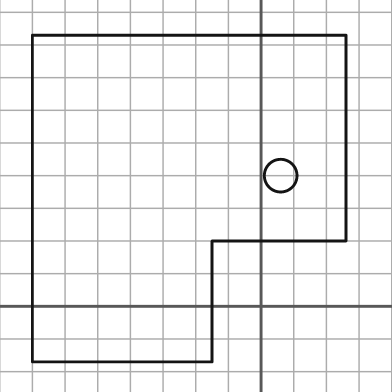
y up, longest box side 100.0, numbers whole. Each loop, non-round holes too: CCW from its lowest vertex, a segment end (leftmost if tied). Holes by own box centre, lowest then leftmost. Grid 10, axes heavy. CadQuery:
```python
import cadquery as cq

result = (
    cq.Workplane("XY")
    .moveTo(-70.0, -17.0)
    .lineTo(-15.0, -17.0)
    .lineTo(-15.0, 20.0)
    .lineTo(26.0, 20.0)
    .lineTo(26.0, 83.0)
    .lineTo(-70.0, 83.0)
    .close()
    .moveTo(6.0, 40.0)
    .circle(5.0)
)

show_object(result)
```